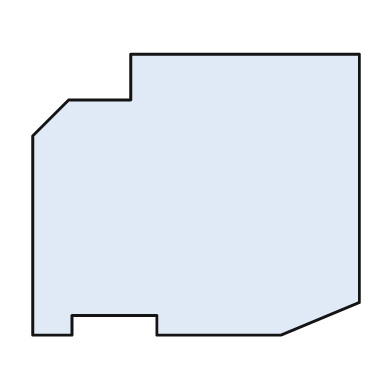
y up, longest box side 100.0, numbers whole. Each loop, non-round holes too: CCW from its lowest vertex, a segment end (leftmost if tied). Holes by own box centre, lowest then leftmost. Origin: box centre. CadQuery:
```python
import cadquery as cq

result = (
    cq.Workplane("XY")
    .moveTo(-50.0, -43.0)
    .lineTo(-38.0, -43.0)
    .lineTo(-38.0, -37.0)
    .lineTo(-12.0, -37.0)
    .lineTo(-12.0, -43.0)
    .lineTo(26.0, -43.0)
    .lineTo(50.0, -33.0)
    .lineTo(50.0, 43.0)
    .lineTo(-20.0, 43.0)
    .lineTo(-20.0, 29.0)
    .lineTo(-39.0, 29.0)
    .lineTo(-50.0, 18.0)
    .close()
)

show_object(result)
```